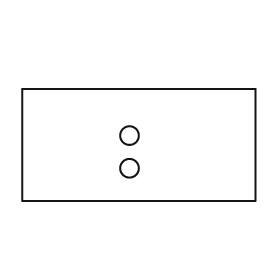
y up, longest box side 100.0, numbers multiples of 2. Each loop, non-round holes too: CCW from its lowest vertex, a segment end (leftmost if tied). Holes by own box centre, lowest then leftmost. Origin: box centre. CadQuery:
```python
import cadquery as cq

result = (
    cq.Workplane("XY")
    .moveTo(-50.0, -24.0)
    .lineTo(50.0, -24.0)
    .lineTo(50.0, 24.0)
    .lineTo(-50.0, 24.0)
    .close()
    .moveTo(-4.0, -10.0)
    .circle(4.0)
    .moveTo(-4.0, 4.0)
    .circle(4.0)
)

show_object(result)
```